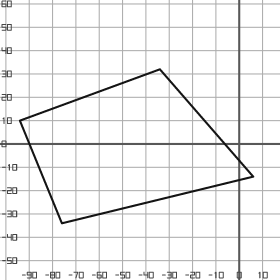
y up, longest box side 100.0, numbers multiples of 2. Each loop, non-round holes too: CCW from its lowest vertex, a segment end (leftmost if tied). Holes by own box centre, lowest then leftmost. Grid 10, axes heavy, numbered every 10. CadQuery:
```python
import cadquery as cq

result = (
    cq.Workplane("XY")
    .moveTo(-76.0, -34.0)
    .lineTo(6.0, -14.0)
    .lineTo(-34.0, 32.0)
    .lineTo(-94.0, 10.0)
    .close()
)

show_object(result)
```